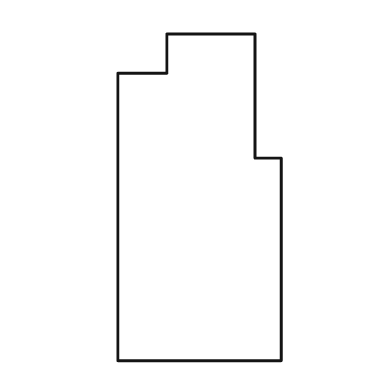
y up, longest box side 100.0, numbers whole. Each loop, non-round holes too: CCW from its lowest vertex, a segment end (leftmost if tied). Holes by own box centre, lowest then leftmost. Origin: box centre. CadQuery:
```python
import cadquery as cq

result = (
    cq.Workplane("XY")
    .moveTo(-25.0, -50.0)
    .lineTo(25.0, -50.0)
    .lineTo(25.0, 12.0)
    .lineTo(17.0, 12.0)
    .lineTo(17.0, 50.0)
    .lineTo(-10.0, 50.0)
    .lineTo(-10.0, 38.0)
    .lineTo(-25.0, 38.0)
    .close()
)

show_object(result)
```